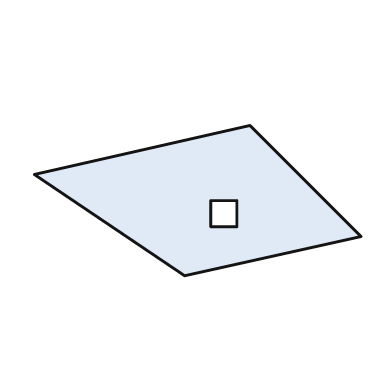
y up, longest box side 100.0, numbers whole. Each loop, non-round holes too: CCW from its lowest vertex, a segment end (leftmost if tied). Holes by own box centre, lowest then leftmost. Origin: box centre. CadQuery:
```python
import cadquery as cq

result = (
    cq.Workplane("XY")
    .moveTo(-4.0, -23.0)
    .lineTo(50.0, -11.0)
    .lineTo(16.0, 23.0)
    .lineTo(-50.0, 8.0)
    .close()
    .moveTo(4.0, -8.0)
    .lineTo(12.0, -8.0)
    .lineTo(12.0, 0.0)
    .lineTo(4.0, 0.0)
    .close()
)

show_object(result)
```